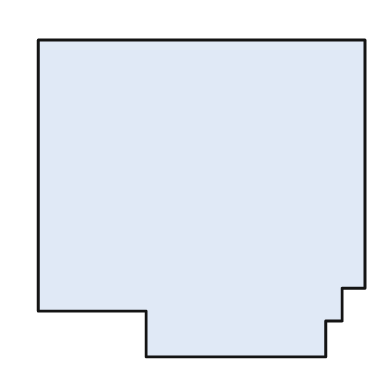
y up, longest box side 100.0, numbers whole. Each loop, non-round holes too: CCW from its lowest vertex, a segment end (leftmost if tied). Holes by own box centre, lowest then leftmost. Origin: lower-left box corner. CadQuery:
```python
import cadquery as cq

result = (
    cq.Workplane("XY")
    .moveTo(33.0, 0.0)
    .lineTo(88.0, 0.0)
    .lineTo(88.0, 11.0)
    .lineTo(93.0, 11.0)
    .lineTo(93.0, 21.0)
    .lineTo(100.0, 21.0)
    .lineTo(100.0, 97.0)
    .lineTo(0.0, 97.0)
    .lineTo(0.0, 14.0)
    .lineTo(33.0, 14.0)
    .close()
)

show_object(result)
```